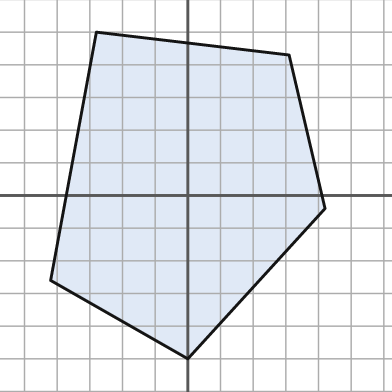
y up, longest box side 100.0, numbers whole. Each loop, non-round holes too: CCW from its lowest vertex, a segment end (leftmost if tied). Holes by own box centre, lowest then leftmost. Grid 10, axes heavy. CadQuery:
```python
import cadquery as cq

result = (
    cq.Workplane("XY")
    .moveTo(0.0, -50.0)
    .lineTo(42.0, -4.0)
    .lineTo(31.0, 43.0)
    .lineTo(-28.0, 50.0)
    .lineTo(-42.0, -26.0)
    .close()
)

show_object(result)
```